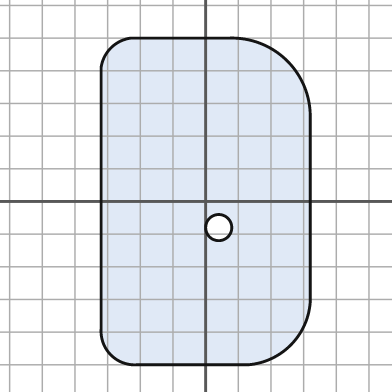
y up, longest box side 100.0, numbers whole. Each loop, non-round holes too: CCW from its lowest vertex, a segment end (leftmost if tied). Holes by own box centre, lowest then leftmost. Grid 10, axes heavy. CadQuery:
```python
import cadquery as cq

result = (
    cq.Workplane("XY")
    .moveTo(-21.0, -50.0)
    .lineTo(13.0, -50.0)
    .threePointArc((26.0, -44.0), (32.0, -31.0))
    .lineTo(32.0, 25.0)
    .threePointArc((25.0, 43.0), (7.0, 50.0))
    .lineTo(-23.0, 50.0)
    .threePointArc((-29.0, 47.0), (-32.0, 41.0))
    .lineTo(-32.0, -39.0)
    .threePointArc((-29.0, -47.0), (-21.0, -50.0))
    .close()
    .moveTo(4.0, -8.0)
    .circle(4.0)
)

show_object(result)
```